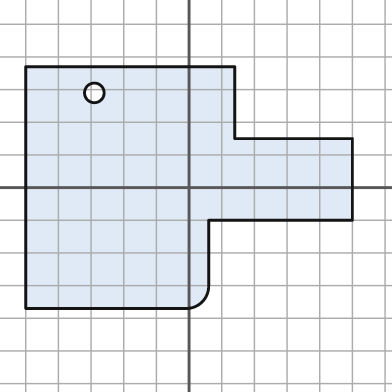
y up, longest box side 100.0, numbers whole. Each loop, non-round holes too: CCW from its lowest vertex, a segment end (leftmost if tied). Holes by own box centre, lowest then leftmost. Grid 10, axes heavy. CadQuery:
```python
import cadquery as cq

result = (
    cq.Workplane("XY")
    .moveTo(-50.0, -37.0)
    .lineTo(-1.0, -37.0)
    .threePointArc((4.0, -35.0), (6.0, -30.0))
    .lineTo(6.0, -10.0)
    .lineTo(50.0, -10.0)
    .lineTo(50.0, 15.0)
    .lineTo(14.0, 15.0)
    .lineTo(14.0, 37.0)
    .lineTo(-50.0, 37.0)
    .close()
    .moveTo(-29.0, 29.0)
    .circle(3.0)
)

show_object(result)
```